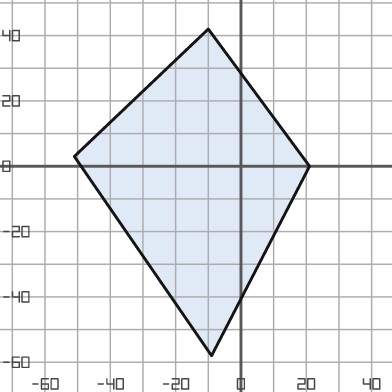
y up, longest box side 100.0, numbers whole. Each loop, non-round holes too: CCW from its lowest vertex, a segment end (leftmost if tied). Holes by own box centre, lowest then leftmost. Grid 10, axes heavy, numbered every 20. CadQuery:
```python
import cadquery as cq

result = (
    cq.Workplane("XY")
    .moveTo(-9.0, -58.0)
    .lineTo(21.0, 0.0)
    .lineTo(-10.0, 42.0)
    .lineTo(-51.0, 3.0)
    .close()
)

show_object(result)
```